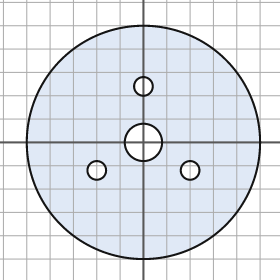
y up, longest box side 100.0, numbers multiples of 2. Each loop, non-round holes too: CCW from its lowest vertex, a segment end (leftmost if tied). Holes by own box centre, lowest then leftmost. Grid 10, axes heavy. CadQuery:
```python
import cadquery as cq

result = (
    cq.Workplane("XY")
    .moveTo(0.0, 0.0)
    .circle(50.0)
    .moveTo(-20.0, -12.0)
    .circle(4.0)
    .moveTo(20.0, -12.0)
    .circle(4.0)
    .moveTo(0.0, 0.0)
    .circle(8.0)
    .moveTo(0.0, 24.0)
    .circle(4.0)
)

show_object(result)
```